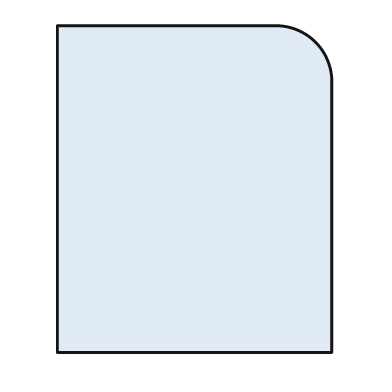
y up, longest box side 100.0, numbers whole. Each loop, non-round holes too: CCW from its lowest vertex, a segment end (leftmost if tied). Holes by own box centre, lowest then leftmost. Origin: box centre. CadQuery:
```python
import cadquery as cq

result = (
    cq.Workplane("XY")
    .moveTo(-42.0, -50.0)
    .lineTo(42.0, -50.0)
    .lineTo(42.0, 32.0)
    .threePointArc((37.0, 45.0), (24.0, 50.0))
    .lineTo(-42.0, 50.0)
    .close()
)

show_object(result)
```